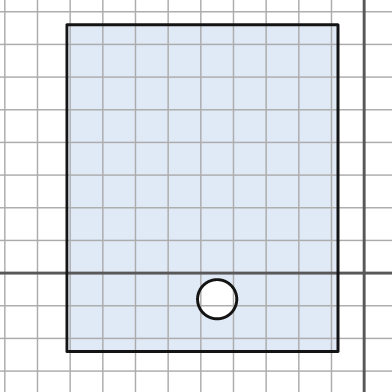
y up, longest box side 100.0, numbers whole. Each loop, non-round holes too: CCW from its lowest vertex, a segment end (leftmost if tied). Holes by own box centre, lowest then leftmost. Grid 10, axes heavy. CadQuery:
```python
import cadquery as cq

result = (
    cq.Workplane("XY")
    .moveTo(-91.0, -24.0)
    .lineTo(-8.0, -24.0)
    .lineTo(-8.0, 76.0)
    .lineTo(-91.0, 76.0)
    .close()
    .moveTo(-45.0, -8.0)
    .circle(6.0)
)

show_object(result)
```